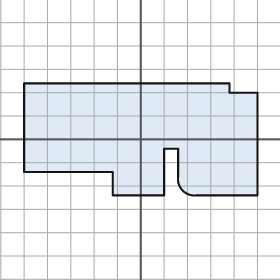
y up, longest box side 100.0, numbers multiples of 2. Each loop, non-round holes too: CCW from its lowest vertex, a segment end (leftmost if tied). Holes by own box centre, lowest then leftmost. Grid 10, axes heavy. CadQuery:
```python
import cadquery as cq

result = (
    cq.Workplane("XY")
    .moveTo(-12.0, -24.0)
    .lineTo(10.0, -24.0)
    .lineTo(10.0, -4.0)
    .lineTo(16.0, -4.0)
    .lineTo(16.0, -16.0)
    .threePointArc((18.0, -22.0), (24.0, -24.0))
    .lineTo(50.0, -24.0)
    .lineTo(50.0, 20.0)
    .lineTo(38.0, 20.0)
    .lineTo(38.0, 24.0)
    .lineTo(-50.0, 24.0)
    .lineTo(-50.0, -14.0)
    .lineTo(-12.0, -14.0)
    .close()
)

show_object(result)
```